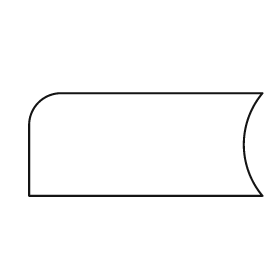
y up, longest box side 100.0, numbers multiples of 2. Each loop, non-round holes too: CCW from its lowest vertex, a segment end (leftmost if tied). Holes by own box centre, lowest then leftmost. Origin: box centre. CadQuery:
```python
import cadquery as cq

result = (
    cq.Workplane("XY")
    .moveTo(-50.0, -22.0)
    .lineTo(50.0, -22.0)
    .threePointArc((42.0, 0.0), (50.0, 22.0))
    .lineTo(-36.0, 22.0)
    .threePointArc((-46.0, 18.0), (-50.0, 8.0))
    .close()
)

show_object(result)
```